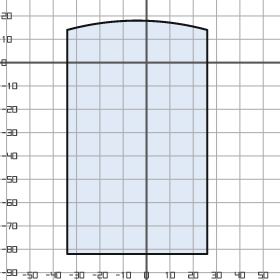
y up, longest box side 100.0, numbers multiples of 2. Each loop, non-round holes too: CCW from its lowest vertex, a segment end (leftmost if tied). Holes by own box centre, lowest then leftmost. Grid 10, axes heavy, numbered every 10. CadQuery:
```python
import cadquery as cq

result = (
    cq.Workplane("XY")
    .moveTo(-34.0, -82.0)
    .lineTo(26.0, -82.0)
    .lineTo(26.0, 14.0)
    .threePointArc((-4.0, 18.0), (-34.0, 14.0))
    .close()
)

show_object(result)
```